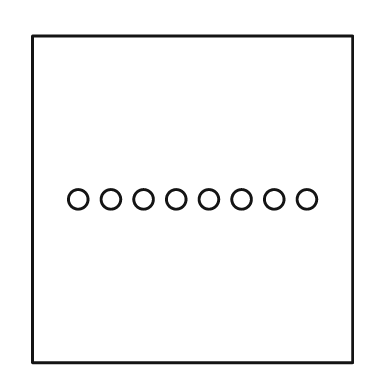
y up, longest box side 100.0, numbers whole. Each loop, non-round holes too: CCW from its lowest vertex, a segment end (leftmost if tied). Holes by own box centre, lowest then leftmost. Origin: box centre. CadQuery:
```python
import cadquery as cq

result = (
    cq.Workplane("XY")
    .moveTo(-49.0, -50.0)
    .lineTo(49.0, -50.0)
    .lineTo(49.0, 50.0)
    .lineTo(-49.0, 50.0)
    .close()
    .moveTo(-35.0, 0.0)
    .circle(3.0)
    .moveTo(-25.0, 0.0)
    .circle(3.0)
    .moveTo(-15.0, 0.0)
    .circle(3.0)
    .moveTo(-5.0, 0.0)
    .circle(3.0)
    .moveTo(5.0, 0.0)
    .circle(3.0)
    .moveTo(15.0, 0.0)
    .circle(3.0)
    .moveTo(25.0, 0.0)
    .circle(3.0)
    .moveTo(35.0, 0.0)
    .circle(3.0)
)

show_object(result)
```